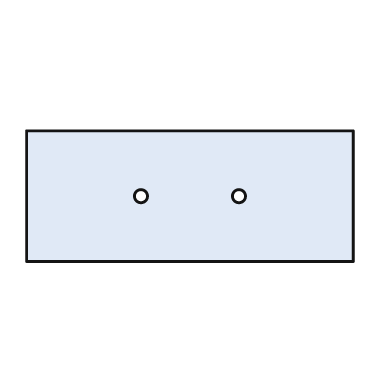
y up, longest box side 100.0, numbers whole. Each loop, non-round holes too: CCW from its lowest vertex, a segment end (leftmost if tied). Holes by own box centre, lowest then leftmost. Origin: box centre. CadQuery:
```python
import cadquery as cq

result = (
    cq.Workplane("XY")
    .moveTo(-50.0, -20.0)
    .lineTo(50.0, -20.0)
    .lineTo(50.0, 20.0)
    .lineTo(-50.0, 20.0)
    .close()
    .moveTo(-15.0, 0.0)
    .circle(2.0)
    .moveTo(15.0, 0.0)
    .circle(2.0)
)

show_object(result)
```